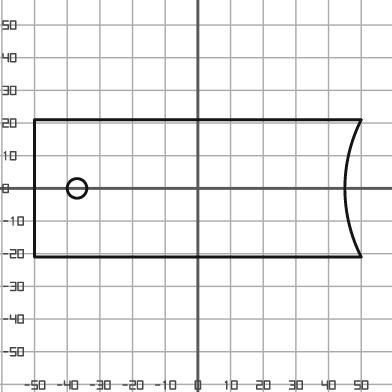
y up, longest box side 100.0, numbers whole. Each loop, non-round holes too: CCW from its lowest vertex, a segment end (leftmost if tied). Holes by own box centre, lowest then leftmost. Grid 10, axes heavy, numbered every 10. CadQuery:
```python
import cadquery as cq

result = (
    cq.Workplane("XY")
    .moveTo(-50.0, -21.0)
    .lineTo(50.0, -21.0)
    .threePointArc((45.0, 0.0), (50.0, 21.0))
    .lineTo(-50.0, 21.0)
    .close()
    .moveTo(-37.0, 0.0)
    .circle(3.0)
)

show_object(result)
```